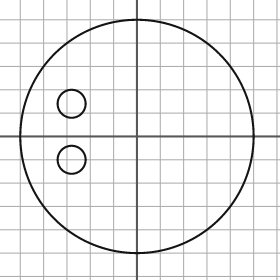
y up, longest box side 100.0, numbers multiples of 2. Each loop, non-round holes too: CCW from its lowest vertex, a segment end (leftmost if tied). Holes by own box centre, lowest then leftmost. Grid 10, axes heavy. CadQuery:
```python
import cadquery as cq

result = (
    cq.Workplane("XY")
    .moveTo(0.0, 0.0)
    .circle(50.0)
    .moveTo(-28.0, -10.0)
    .circle(6.0)
    .moveTo(-28.0, 14.0)
    .circle(6.0)
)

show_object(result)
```